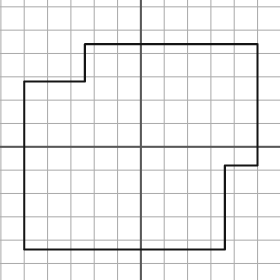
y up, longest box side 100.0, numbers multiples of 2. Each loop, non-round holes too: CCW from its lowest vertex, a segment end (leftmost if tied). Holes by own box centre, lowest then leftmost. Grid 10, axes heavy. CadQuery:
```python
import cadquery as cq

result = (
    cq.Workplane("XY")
    .moveTo(-50.0, -44.0)
    .lineTo(36.0, -44.0)
    .lineTo(36.0, -8.0)
    .lineTo(50.0, -8.0)
    .lineTo(50.0, 44.0)
    .lineTo(-24.0, 44.0)
    .lineTo(-24.0, 28.0)
    .lineTo(-50.0, 28.0)
    .close()
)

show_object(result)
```